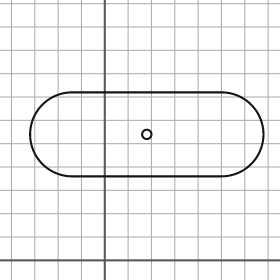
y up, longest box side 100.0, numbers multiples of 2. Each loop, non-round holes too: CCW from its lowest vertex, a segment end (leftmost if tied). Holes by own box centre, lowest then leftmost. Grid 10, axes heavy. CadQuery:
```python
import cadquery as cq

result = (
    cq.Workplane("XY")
    .moveTo(-14.0, 36.0)
    .lineTo(50.0, 36.0)
    .threePointArc((68.0, 54.0), (50.0, 72.0))
    .lineTo(-14.0, 72.0)
    .threePointArc((-32.0, 54.0), (-14.0, 36.0))
    .close()
    .moveTo(18.0, 54.0)
    .circle(2.0)
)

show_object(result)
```